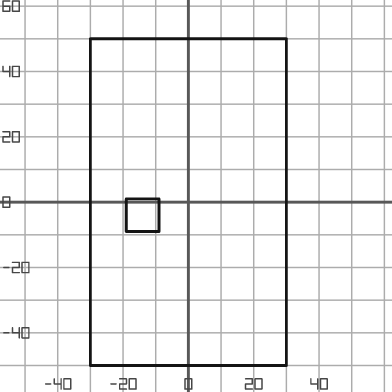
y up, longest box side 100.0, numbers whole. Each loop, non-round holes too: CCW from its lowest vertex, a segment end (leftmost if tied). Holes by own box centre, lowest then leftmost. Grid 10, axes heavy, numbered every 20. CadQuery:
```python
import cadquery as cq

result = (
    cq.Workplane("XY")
    .moveTo(-30.0, -50.0)
    .lineTo(30.0, -50.0)
    .lineTo(30.0, 50.0)
    .lineTo(-30.0, 50.0)
    .close()
    .moveTo(-19.0, -9.0)
    .lineTo(-9.0, -9.0)
    .lineTo(-9.0, 1.0)
    .lineTo(-19.0, 1.0)
    .close()
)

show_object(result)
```